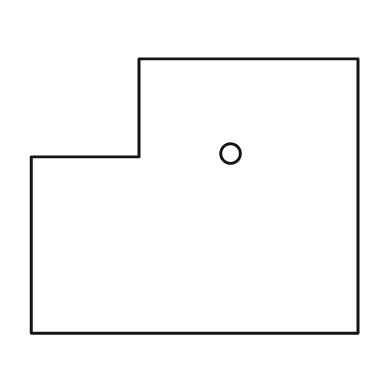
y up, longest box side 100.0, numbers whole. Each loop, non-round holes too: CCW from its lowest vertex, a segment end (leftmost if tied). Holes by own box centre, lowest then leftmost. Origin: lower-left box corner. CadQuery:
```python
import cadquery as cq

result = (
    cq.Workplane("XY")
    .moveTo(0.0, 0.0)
    .lineTo(100.0, 0.0)
    .lineTo(100.0, 84.0)
    .lineTo(33.0, 84.0)
    .lineTo(33.0, 54.0)
    .lineTo(0.0, 54.0)
    .close()
    .moveTo(61.0, 55.0)
    .circle(3.0)
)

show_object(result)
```